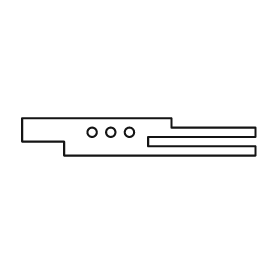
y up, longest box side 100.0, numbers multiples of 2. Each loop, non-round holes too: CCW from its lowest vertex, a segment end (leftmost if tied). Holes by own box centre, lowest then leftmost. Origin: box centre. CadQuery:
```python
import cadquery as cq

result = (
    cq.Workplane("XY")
    .moveTo(-32.0, -8.0)
    .lineTo(50.0, -8.0)
    .lineTo(50.0, -4.0)
    .lineTo(4.0, -4.0)
    .lineTo(4.0, 0.0)
    .lineTo(50.0, 0.0)
    .lineTo(50.0, 4.0)
    .lineTo(14.0, 4.0)
    .lineTo(14.0, 8.0)
    .lineTo(-50.0, 8.0)
    .lineTo(-50.0, -2.0)
    .lineTo(-32.0, -2.0)
    .close()
    .moveTo(-20.0, 2.0)
    .circle(2.0)
    .moveTo(-12.0, 2.0)
    .circle(2.0)
    .moveTo(-4.0, 2.0)
    .circle(2.0)
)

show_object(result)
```